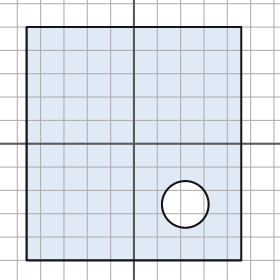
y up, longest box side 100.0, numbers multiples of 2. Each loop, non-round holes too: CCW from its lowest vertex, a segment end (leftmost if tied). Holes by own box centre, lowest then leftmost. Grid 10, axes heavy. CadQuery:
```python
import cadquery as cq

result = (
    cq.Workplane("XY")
    .moveTo(-46.0, -50.0)
    .lineTo(46.0, -50.0)
    .lineTo(46.0, 50.0)
    .lineTo(-46.0, 50.0)
    .close()
    .moveTo(22.0, -26.0)
    .circle(10.0)
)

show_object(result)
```